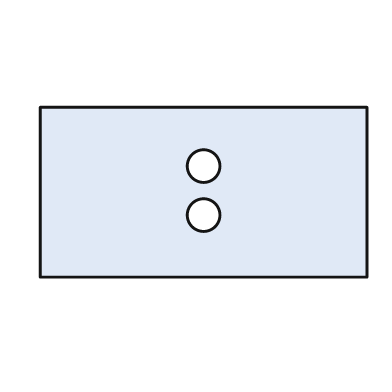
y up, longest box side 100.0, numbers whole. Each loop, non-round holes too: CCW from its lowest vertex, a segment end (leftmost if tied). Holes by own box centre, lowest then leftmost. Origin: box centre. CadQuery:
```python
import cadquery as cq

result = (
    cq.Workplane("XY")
    .moveTo(-50.0, -26.0)
    .lineTo(50.0, -26.0)
    .lineTo(50.0, 26.0)
    .lineTo(-50.0, 26.0)
    .close()
    .moveTo(0.0, -7.0)
    .circle(5.0)
    .moveTo(0.0, 8.0)
    .circle(5.0)
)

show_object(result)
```